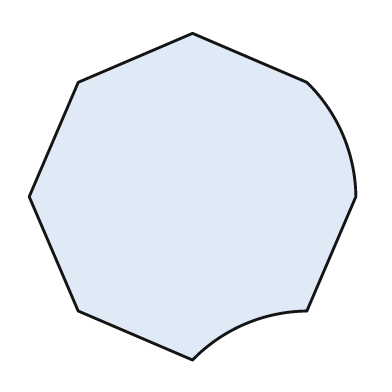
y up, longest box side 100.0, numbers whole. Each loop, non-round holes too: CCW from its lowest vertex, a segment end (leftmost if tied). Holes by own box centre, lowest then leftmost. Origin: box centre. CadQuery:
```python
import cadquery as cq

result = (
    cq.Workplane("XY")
    .moveTo(0.0, -50.0)
    .threePointArc((16.0, -39.0), (35.0, -35.0))
    .lineTo(50.0, 0.0)
    .threePointArc((46.0, 19.0), (35.0, 35.0))
    .lineTo(0.0, 50.0)
    .lineTo(-35.0, 35.0)
    .lineTo(-50.0, 0.0)
    .lineTo(-35.0, -35.0)
    .close()
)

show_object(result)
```